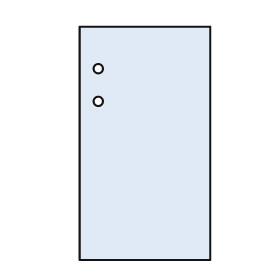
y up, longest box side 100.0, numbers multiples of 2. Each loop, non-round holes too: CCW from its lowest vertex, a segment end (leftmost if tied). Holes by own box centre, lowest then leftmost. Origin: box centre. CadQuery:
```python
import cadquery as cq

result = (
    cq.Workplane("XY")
    .moveTo(-28.0, -50.0)
    .lineTo(28.0, -50.0)
    .lineTo(28.0, 50.0)
    .lineTo(-28.0, 50.0)
    .close()
    .moveTo(-20.0, 18.0)
    .circle(2.0)
    .moveTo(-20.0, 32.0)
    .circle(2.0)
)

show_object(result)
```